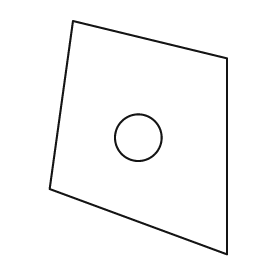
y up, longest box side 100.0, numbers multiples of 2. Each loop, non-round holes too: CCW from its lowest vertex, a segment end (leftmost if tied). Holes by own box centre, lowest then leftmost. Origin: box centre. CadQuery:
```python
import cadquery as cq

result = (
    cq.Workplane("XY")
    .moveTo(38.0, -50.0)
    .lineTo(38.0, 34.0)
    .lineTo(-28.0, 50.0)
    .lineTo(-38.0, -22.0)
    .close()
    .moveTo(0.0, 0.0)
    .circle(10.0)
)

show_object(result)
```